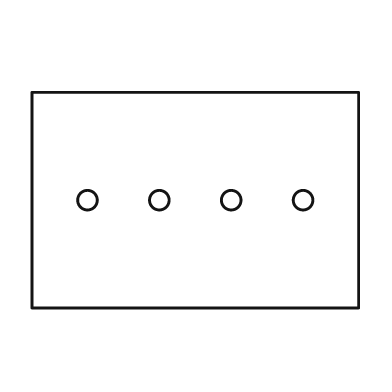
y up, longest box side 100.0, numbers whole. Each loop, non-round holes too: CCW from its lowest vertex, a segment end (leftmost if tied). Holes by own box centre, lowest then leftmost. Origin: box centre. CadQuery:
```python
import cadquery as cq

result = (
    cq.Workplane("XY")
    .moveTo(-50.0, -33.0)
    .lineTo(50.0, -33.0)
    .lineTo(50.0, 33.0)
    .lineTo(-50.0, 33.0)
    .close()
    .moveTo(-33.0, 0.0)
    .circle(3.0)
    .moveTo(-11.0, 0.0)
    .circle(3.0)
    .moveTo(11.0, 0.0)
    .circle(3.0)
    .moveTo(33.0, 0.0)
    .circle(3.0)
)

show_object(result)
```